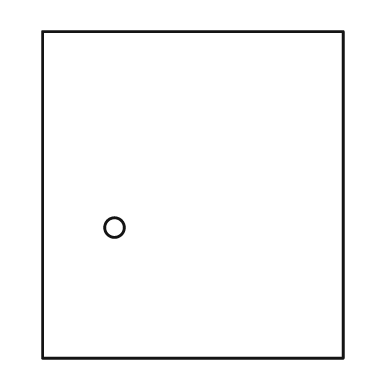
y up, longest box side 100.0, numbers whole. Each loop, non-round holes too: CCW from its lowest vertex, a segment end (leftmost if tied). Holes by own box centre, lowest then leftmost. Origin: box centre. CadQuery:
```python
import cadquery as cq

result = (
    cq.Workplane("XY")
    .moveTo(-46.0, -50.0)
    .lineTo(46.0, -50.0)
    .lineTo(46.0, 50.0)
    .lineTo(-46.0, 50.0)
    .close()
    .moveTo(-24.0, -10.0)
    .circle(3.0)
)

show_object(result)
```